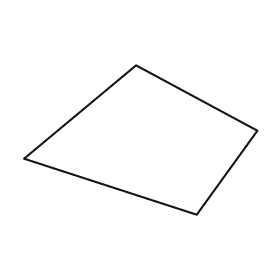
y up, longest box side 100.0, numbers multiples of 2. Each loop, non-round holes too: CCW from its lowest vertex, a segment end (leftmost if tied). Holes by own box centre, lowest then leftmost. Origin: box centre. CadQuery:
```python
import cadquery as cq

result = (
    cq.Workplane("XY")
    .moveTo(24.0, -32.0)
    .lineTo(50.0, 4.0)
    .lineTo(-2.0, 32.0)
    .lineTo(-50.0, -8.0)
    .close()
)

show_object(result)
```